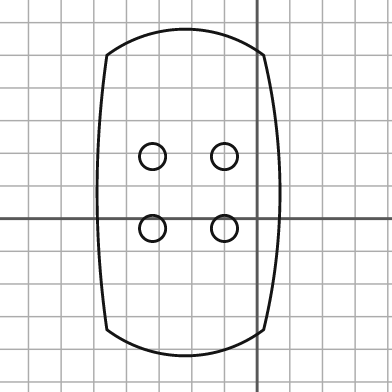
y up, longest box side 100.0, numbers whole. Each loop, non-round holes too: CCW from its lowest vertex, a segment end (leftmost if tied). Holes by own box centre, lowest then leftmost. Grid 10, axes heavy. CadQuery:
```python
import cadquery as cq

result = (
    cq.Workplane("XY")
    .moveTo(-46.0, -34.0)
    .threePointArc((-22.0, -42.0), (2.0, -34.0))
    .threePointArc((7.0, 8.0), (2.0, 50.0))
    .threePointArc((-22.0, 58.0), (-46.0, 50.0))
    .threePointArc((-49.0, 8.0), (-46.0, -34.0))
    .close()
    .moveTo(-32.0, -3.0)
    .circle(4.0)
    .moveTo(-10.0, -3.0)
    .circle(4.0)
    .moveTo(-32.0, 19.0)
    .circle(4.0)
    .moveTo(-10.0, 19.0)
    .circle(4.0)
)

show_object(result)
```